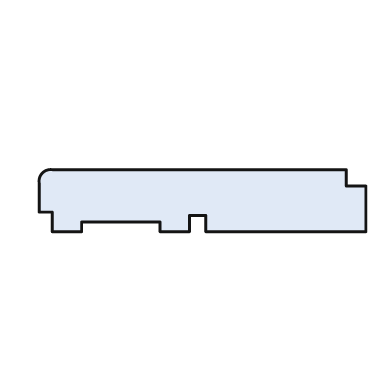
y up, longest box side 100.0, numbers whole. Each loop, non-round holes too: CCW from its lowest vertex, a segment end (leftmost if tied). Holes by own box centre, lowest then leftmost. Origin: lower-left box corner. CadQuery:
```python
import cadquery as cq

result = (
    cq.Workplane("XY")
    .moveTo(4.0, 0.0)
    .lineTo(13.0, 0.0)
    .lineTo(13.0, 3.0)
    .lineTo(37.0, 3.0)
    .lineTo(37.0, 0.0)
    .lineTo(46.0, 0.0)
    .lineTo(46.0, 5.0)
    .lineTo(51.0, 5.0)
    .lineTo(51.0, 0.0)
    .lineTo(100.0, 0.0)
    .lineTo(100.0, 14.0)
    .lineTo(94.0, 14.0)
    .lineTo(94.0, 19.0)
    .lineTo(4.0, 19.0)
    .threePointArc((1.0, 18.0), (0.0, 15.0))
    .lineTo(0.0, 6.0)
    .lineTo(4.0, 6.0)
    .close()
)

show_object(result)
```